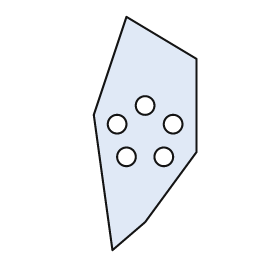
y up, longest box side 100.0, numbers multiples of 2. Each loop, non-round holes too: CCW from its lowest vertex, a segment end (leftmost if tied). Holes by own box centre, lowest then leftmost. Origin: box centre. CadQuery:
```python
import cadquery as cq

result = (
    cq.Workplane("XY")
    .moveTo(-14.0, -50.0)
    .lineTo(0.0, -38.0)
    .lineTo(22.0, -8.0)
    .lineTo(22.0, 32.0)
    .lineTo(-8.0, 50.0)
    .lineTo(-22.0, 8.0)
    .close()
    .moveTo(-8.0, -10.0)
    .circle(4.0)
    .moveTo(8.0, -10.0)
    .circle(4.0)
    .moveTo(-12.0, 4.0)
    .circle(4.0)
    .moveTo(12.0, 4.0)
    .circle(4.0)
    .moveTo(0.0, 12.0)
    .circle(4.0)
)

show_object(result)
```